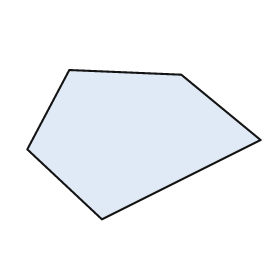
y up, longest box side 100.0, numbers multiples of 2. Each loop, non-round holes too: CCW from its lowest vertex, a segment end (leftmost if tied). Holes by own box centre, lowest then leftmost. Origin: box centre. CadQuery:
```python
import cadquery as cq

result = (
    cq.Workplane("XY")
    .moveTo(-18.0, -32.0)
    .lineTo(50.0, 2.0)
    .lineTo(16.0, 30.0)
    .lineTo(-32.0, 32.0)
    .lineTo(-50.0, -2.0)
    .close()
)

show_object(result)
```